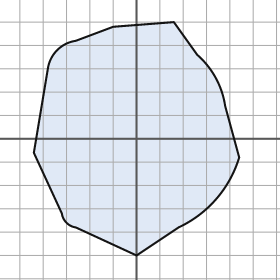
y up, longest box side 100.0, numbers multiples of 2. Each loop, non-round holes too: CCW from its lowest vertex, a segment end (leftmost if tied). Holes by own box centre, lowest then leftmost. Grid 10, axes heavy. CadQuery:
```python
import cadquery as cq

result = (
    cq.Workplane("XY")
    .moveTo(0.0, -50.0)
    .lineTo(18.0, -38.0)
    .threePointArc((34.0, -26.0), (44.0, -8.0))
    .lineTo(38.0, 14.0)
    .threePointArc((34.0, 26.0), (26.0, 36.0))
    .lineTo(16.0, 50.0)
    .lineTo(-10.0, 48.0)
    .lineTo(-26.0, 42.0)
    .threePointArc((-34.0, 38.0), (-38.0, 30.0))
    .lineTo(-44.0, -6.0)
    .lineTo(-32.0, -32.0)
    .threePointArc((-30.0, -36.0), (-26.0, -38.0))
    .close()
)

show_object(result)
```